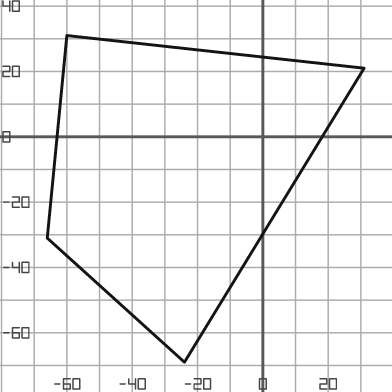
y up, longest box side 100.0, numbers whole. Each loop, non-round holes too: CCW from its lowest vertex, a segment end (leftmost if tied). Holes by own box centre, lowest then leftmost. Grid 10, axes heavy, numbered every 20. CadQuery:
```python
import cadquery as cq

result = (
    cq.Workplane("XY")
    .moveTo(-24.0, -69.0)
    .lineTo(31.0, 21.0)
    .lineTo(-60.0, 31.0)
    .lineTo(-66.0, -31.0)
    .close()
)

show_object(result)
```